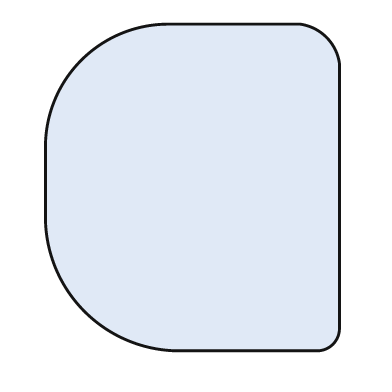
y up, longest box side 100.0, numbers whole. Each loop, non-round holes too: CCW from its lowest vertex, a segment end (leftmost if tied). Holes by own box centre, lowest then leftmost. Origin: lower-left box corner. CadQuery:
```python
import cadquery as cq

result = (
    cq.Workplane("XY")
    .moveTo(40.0, 0.0)
    .lineTo(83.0, 0.0)
    .threePointArc((88.0, 2.0), (90.0, 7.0))
    .lineTo(90.0, 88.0)
    .threePointArc((86.0, 96.0), (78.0, 100.0))
    .lineTo(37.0, 100.0)
    .threePointArc((11.0, 89.0), (0.0, 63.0))
    .lineTo(0.0, 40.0)
    .threePointArc((12.0, 12.0), (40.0, 0.0))
    .close()
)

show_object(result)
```